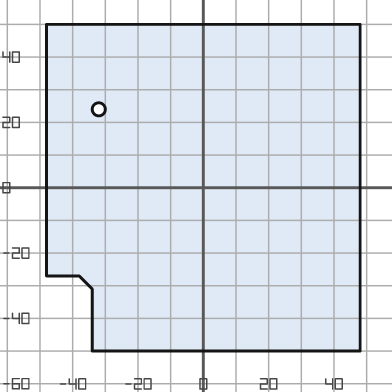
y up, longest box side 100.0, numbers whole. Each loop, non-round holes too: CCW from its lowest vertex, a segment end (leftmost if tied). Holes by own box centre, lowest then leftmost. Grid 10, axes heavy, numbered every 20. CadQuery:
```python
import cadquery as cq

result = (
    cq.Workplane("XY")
    .moveTo(-34.0, -50.0)
    .lineTo(48.0, -50.0)
    .lineTo(48.0, 50.0)
    .lineTo(-48.0, 50.0)
    .lineTo(-48.0, -27.0)
    .lineTo(-38.0, -27.0)
    .lineTo(-34.0, -31.0)
    .close()
    .moveTo(-32.0, 24.0)
    .circle(2.0)
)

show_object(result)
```